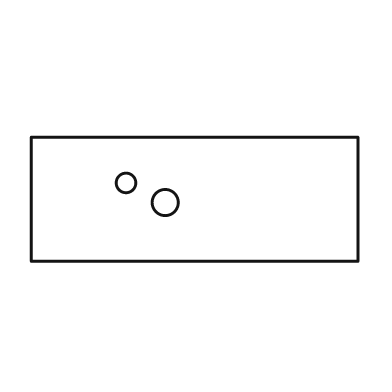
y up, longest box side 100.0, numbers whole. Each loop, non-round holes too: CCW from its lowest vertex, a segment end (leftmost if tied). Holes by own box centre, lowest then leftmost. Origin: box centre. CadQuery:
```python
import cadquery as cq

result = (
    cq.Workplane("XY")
    .moveTo(-50.0, -19.0)
    .lineTo(50.0, -19.0)
    .lineTo(50.0, 19.0)
    .lineTo(-50.0, 19.0)
    .close()
    .moveTo(-9.0, -1.0)
    .circle(4.0)
    .moveTo(-21.0, 5.0)
    .circle(3.0)
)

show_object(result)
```